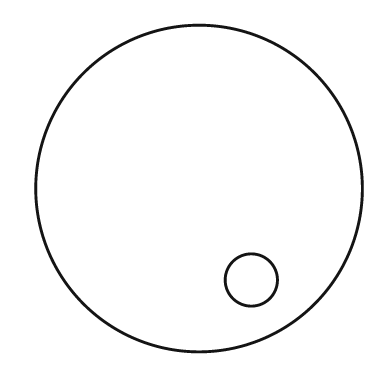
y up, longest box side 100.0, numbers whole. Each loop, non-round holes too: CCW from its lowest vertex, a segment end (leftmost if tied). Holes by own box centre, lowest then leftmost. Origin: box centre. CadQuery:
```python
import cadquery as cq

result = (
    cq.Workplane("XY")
    .moveTo(0.0, 0.0)
    .circle(50.0)
    .moveTo(16.0, -28.0)
    .circle(8.0)
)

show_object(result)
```